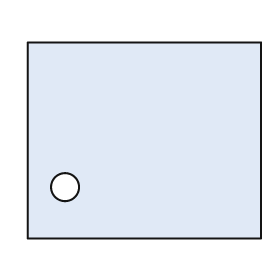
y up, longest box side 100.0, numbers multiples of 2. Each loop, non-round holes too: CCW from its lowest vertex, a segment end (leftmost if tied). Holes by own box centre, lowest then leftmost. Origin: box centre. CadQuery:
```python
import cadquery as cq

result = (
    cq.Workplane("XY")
    .moveTo(-50.0, -42.0)
    .lineTo(50.0, -42.0)
    .lineTo(50.0, 42.0)
    .lineTo(-50.0, 42.0)
    .close()
    .moveTo(-34.0, -20.0)
    .circle(6.0)
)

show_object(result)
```